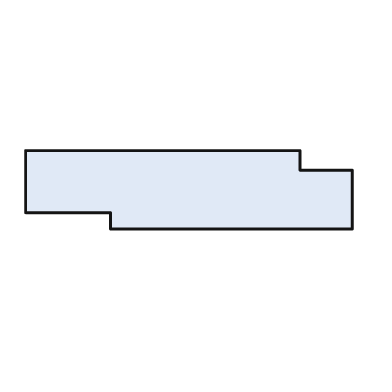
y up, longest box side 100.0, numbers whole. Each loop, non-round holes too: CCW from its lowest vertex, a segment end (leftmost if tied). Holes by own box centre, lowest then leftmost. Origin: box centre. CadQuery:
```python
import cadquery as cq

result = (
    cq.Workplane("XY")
    .moveTo(-24.0, -12.0)
    .lineTo(50.0, -12.0)
    .lineTo(50.0, 6.0)
    .lineTo(34.0, 6.0)
    .lineTo(34.0, 12.0)
    .lineTo(-50.0, 12.0)
    .lineTo(-50.0, -7.0)
    .lineTo(-24.0, -7.0)
    .close()
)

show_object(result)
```